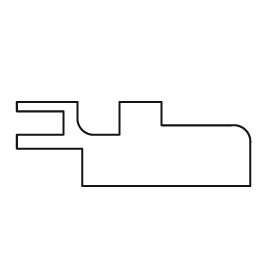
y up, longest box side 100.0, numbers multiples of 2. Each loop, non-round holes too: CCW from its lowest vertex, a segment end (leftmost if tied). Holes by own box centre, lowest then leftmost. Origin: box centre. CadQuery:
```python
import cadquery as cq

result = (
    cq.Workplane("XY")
    .moveTo(-22.0, -18.0)
    .lineTo(50.0, -18.0)
    .lineTo(50.0, 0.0)
    .threePointArc((48.0, 6.0), (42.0, 8.0))
    .lineTo(12.0, 8.0)
    .lineTo(12.0, 18.0)
    .lineTo(-6.0, 18.0)
    .lineTo(-6.0, 4.0)
    .lineTo(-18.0, 4.0)
    .threePointArc((-22.0, 6.0), (-24.0, 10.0))
    .lineTo(-24.0, 18.0)
    .lineTo(-50.0, 18.0)
    .lineTo(-50.0, 14.0)
    .lineTo(-30.0, 14.0)
    .lineTo(-30.0, 4.0)
    .lineTo(-50.0, 4.0)
    .lineTo(-50.0, -2.0)
    .lineTo(-22.0, -2.0)
    .close()
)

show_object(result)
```